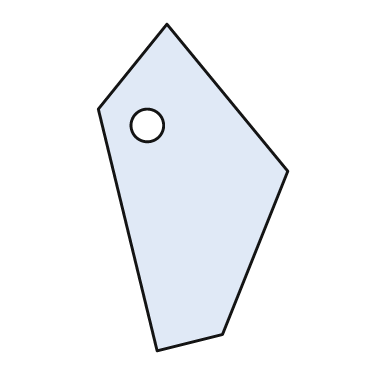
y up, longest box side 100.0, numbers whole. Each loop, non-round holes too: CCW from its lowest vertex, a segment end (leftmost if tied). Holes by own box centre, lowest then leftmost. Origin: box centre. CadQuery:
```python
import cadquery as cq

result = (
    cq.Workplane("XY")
    .moveTo(-11.0, -50.0)
    .lineTo(9.0, -45.0)
    .lineTo(29.0, 5.0)
    .lineTo(-8.0, 50.0)
    .lineTo(-29.0, 24.0)
    .close()
    .moveTo(-14.0, 19.0)
    .circle(5.0)
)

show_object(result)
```